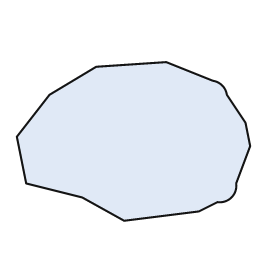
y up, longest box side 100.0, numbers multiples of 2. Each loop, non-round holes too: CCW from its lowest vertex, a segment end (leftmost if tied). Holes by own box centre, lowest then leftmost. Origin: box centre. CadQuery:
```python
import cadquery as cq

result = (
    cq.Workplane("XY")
    .moveTo(-4.0, -34.0)
    .lineTo(28.0, -30.0)
    .lineTo(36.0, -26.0)
    .threePointArc((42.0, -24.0), (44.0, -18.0))
    .lineTo(50.0, -2.0)
    .lineTo(48.0, 8.0)
    .lineTo(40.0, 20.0)
    .threePointArc((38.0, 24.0), (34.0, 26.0))
    .lineTo(14.0, 34.0)
    .lineTo(-16.0, 32.0)
    .lineTo(-36.0, 20.0)
    .lineTo(-50.0, 2.0)
    .lineTo(-46.0, -18.0)
    .lineTo(-22.0, -24.0)
    .close()
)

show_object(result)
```